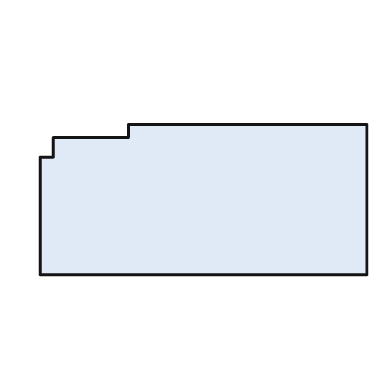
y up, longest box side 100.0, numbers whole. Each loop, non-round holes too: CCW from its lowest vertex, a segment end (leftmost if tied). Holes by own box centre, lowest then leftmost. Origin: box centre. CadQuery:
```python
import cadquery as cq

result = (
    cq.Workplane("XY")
    .moveTo(-50.0, -23.0)
    .lineTo(50.0, -23.0)
    .lineTo(50.0, 23.0)
    .lineTo(-23.0, 23.0)
    .lineTo(-23.0, 19.0)
    .lineTo(-46.0, 19.0)
    .lineTo(-46.0, 13.0)
    .lineTo(-50.0, 13.0)
    .close()
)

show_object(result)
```